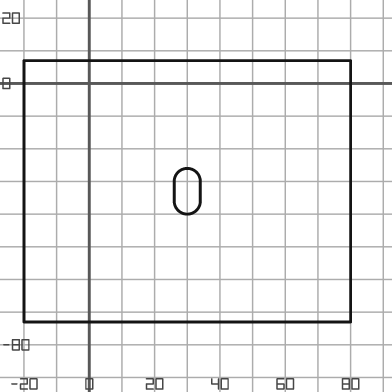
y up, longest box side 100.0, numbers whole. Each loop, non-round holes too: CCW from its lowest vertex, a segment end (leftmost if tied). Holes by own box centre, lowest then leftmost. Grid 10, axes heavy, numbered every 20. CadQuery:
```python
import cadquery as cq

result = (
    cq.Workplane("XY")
    .moveTo(-20.0, -73.0)
    .lineTo(80.0, -73.0)
    .lineTo(80.0, 7.0)
    .lineTo(-20.0, 7.0)
    .close()
    .moveTo(26.0, -36.0)
    .threePointArc((30.0, -40.0), (34.0, -36.0))
    .lineTo(34.0, -30.0)
    .threePointArc((30.0, -26.0), (26.0, -30.0))
    .close()
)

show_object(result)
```